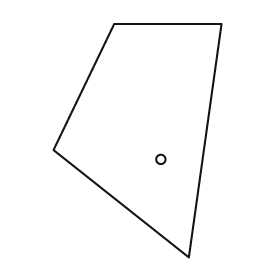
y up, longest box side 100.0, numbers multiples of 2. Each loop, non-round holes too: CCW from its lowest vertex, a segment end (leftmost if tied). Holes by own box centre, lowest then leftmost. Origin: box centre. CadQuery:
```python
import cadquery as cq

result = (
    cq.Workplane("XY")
    .moveTo(22.0, -50.0)
    .lineTo(36.0, 50.0)
    .lineTo(-10.0, 50.0)
    .lineTo(-36.0, -4.0)
    .close()
    .moveTo(10.0, -8.0)
    .circle(2.0)
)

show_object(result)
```